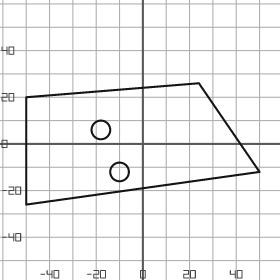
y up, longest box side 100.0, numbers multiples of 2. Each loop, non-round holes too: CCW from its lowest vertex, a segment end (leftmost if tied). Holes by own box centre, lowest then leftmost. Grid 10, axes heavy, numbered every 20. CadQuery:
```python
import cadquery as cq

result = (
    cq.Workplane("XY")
    .moveTo(-50.0, -26.0)
    .lineTo(50.0, -12.0)
    .lineTo(24.0, 26.0)
    .lineTo(-50.0, 20.0)
    .close()
    .moveTo(-10.0, -12.0)
    .circle(4.0)
    .moveTo(-18.0, 6.0)
    .circle(4.0)
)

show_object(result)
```